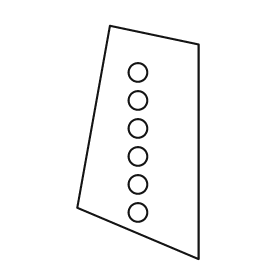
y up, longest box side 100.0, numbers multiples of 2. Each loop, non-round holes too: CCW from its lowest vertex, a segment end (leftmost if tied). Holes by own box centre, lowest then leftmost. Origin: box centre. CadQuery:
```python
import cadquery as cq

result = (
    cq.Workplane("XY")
    .moveTo(26.0, -50.0)
    .lineTo(26.0, 42.0)
    .lineTo(-12.0, 50.0)
    .lineTo(-26.0, -28.0)
    .close()
    .moveTo(0.0, -30.0)
    .circle(4.0)
    .moveTo(0.0, -18.0)
    .circle(4.0)
    .moveTo(0.0, -6.0)
    .circle(4.0)
    .moveTo(0.0, 6.0)
    .circle(4.0)
    .moveTo(0.0, 18.0)
    .circle(4.0)
    .moveTo(0.0, 30.0)
    .circle(4.0)
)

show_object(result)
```